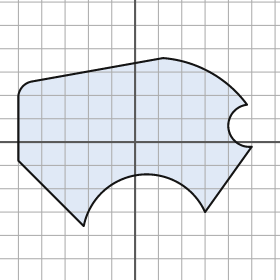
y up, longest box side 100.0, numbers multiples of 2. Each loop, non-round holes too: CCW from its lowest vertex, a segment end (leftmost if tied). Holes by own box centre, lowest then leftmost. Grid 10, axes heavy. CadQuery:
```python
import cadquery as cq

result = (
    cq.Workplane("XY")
    .moveTo(-22.0, -36.0)
    .threePointArc((2.0, -14.0), (30.0, -30.0))
    .lineTo(50.0, -2.0)
    .threePointArc((40.0, 6.0), (48.0, 16.0))
    .threePointArc((32.0, 30.0), (12.0, 36.0))
    .lineTo(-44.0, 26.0)
    .threePointArc((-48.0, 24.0), (-50.0, 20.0))
    .lineTo(-50.0, -8.0)
    .close()
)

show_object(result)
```